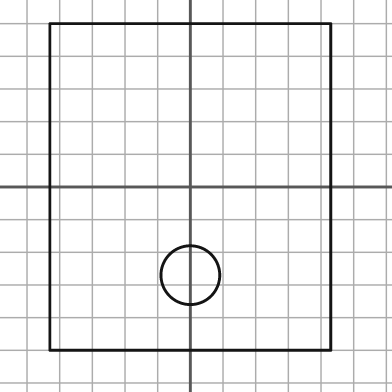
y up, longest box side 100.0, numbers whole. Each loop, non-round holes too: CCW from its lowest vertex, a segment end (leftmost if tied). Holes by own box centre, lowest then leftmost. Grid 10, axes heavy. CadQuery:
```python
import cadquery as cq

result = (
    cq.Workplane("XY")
    .moveTo(-43.0, -50.0)
    .lineTo(43.0, -50.0)
    .lineTo(43.0, 50.0)
    .lineTo(-43.0, 50.0)
    .close()
    .moveTo(0.0, -27.0)
    .circle(9.0)
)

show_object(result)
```